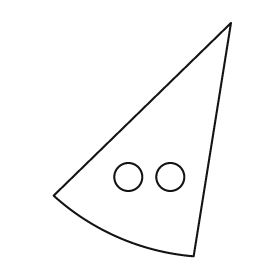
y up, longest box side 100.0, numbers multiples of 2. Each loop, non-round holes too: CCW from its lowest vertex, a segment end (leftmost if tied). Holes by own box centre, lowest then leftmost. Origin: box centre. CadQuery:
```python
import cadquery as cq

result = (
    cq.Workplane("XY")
    .moveTo(22.0, -50.0)
    .lineTo(38.0, 50.0)
    .lineTo(-38.0, -24.0)
    .threePointArc((-10.0, -42.0), (22.0, -50.0))
    .close()
    .moveTo(-6.0, -16.0)
    .circle(6.0)
    .moveTo(12.0, -16.0)
    .circle(6.0)
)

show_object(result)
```